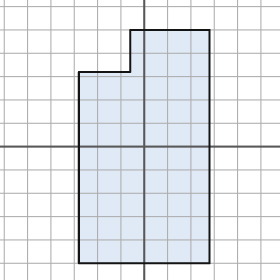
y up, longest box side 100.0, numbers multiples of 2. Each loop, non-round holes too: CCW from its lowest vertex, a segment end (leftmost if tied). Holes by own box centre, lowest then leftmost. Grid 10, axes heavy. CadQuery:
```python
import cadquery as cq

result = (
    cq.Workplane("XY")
    .moveTo(-28.0, -50.0)
    .lineTo(28.0, -50.0)
    .lineTo(28.0, 50.0)
    .lineTo(-6.0, 50.0)
    .lineTo(-6.0, 32.0)
    .lineTo(-28.0, 32.0)
    .close()
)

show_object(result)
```